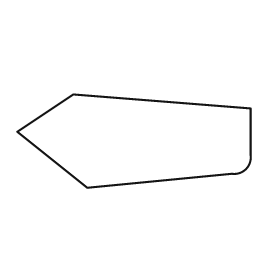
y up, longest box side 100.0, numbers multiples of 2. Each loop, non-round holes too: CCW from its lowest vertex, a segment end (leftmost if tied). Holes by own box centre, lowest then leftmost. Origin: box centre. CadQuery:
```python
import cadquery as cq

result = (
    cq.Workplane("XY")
    .moveTo(-20.0, -20.0)
    .lineTo(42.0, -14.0)
    .threePointArc((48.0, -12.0), (50.0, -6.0))
    .lineTo(50.0, 14.0)
    .lineTo(-26.0, 20.0)
    .lineTo(-50.0, 4.0)
    .close()
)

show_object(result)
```